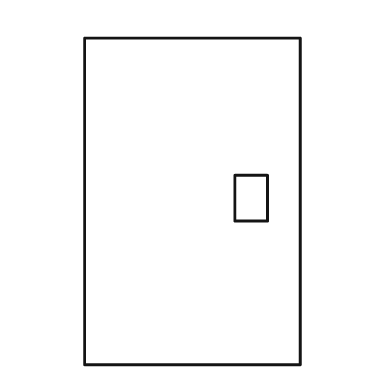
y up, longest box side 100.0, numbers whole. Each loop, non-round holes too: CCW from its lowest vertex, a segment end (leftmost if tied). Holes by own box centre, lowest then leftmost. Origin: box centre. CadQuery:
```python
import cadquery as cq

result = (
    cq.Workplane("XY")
    .moveTo(-33.0, -50.0)
    .lineTo(33.0, -50.0)
    .lineTo(33.0, 50.0)
    .lineTo(-33.0, 50.0)
    .close()
    .moveTo(13.0, -6.0)
    .lineTo(23.0, -6.0)
    .lineTo(23.0, 8.0)
    .lineTo(13.0, 8.0)
    .close()
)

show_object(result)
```